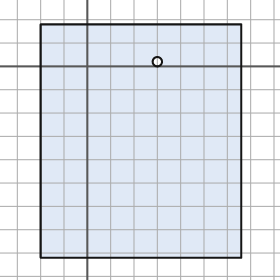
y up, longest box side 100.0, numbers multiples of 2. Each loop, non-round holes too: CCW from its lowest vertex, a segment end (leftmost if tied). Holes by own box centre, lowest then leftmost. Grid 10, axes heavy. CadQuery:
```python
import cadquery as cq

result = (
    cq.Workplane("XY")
    .moveTo(-20.0, -82.0)
    .lineTo(66.0, -82.0)
    .lineTo(66.0, 18.0)
    .lineTo(-20.0, 18.0)
    .close()
    .moveTo(30.0, 2.0)
    .circle(2.0)
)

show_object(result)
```